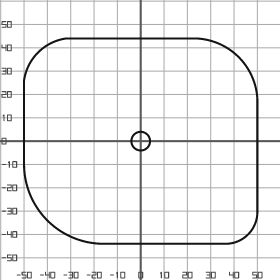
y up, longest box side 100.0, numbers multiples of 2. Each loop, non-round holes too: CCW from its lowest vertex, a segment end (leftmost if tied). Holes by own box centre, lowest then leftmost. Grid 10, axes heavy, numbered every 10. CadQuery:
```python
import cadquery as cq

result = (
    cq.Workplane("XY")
    .moveTo(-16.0, -44.0)
    .lineTo(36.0, -44.0)
    .threePointArc((46.0, -40.0), (50.0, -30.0))
    .lineTo(50.0, 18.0)
    .threePointArc((42.0, 36.0), (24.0, 44.0))
    .lineTo(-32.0, 44.0)
    .threePointArc((-44.0, 38.0), (-50.0, 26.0))
    .lineTo(-50.0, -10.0)
    .threePointArc((-40.0, -34.0), (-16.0, -44.0))
    .close()
    .moveTo(0.0, 0.0)
    .circle(4.0)
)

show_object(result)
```